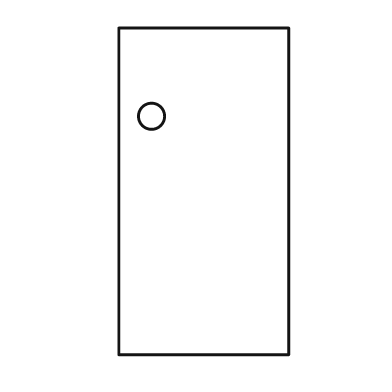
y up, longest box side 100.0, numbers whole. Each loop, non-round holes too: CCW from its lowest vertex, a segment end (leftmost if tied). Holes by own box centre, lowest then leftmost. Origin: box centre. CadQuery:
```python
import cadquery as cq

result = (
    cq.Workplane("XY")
    .moveTo(-26.0, -50.0)
    .lineTo(26.0, -50.0)
    .lineTo(26.0, 50.0)
    .lineTo(-26.0, 50.0)
    .close()
    .moveTo(-16.0, 23.0)
    .circle(4.0)
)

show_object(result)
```